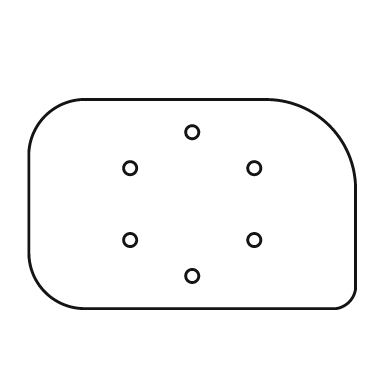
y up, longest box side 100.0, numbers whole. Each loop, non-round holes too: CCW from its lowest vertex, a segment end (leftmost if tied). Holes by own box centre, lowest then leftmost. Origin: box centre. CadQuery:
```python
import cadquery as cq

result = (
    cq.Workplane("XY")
    .moveTo(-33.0, -32.0)
    .lineTo(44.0, -32.0)
    .threePointArc((48.0, -30.0), (50.0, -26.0))
    .lineTo(50.0, 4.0)
    .threePointArc((42.0, 24.0), (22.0, 32.0))
    .lineTo(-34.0, 32.0)
    .threePointArc((-45.0, 27.0), (-50.0, 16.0))
    .lineTo(-50.0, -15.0)
    .threePointArc((-45.0, -27.0), (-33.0, -32.0))
    .close()
    .moveTo(0.0, -22.0)
    .circle(2.0)
    .moveTo(-19.0, -11.0)
    .circle(2.0)
    .moveTo(19.0, -11.0)
    .circle(2.0)
    .moveTo(-19.0, 11.0)
    .circle(2.0)
    .moveTo(19.0, 11.0)
    .circle(2.0)
    .moveTo(0.0, 22.0)
    .circle(2.0)
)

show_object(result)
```